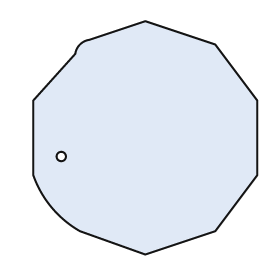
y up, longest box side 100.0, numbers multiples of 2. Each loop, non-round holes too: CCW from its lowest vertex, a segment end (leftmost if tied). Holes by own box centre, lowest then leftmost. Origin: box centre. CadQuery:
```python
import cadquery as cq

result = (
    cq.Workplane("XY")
    .moveTo(0.0, -50.0)
    .lineTo(30.0, -40.0)
    .lineTo(48.0, -16.0)
    .lineTo(48.0, 16.0)
    .lineTo(30.0, 40.0)
    .lineTo(0.0, 50.0)
    .lineTo(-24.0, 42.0)
    .threePointArc((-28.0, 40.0), (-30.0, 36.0))
    .lineTo(-48.0, 16.0)
    .lineTo(-48.0, -16.0)
    .threePointArc((-40.0, -30.0), (-28.0, -40.0))
    .close()
    .moveTo(-36.0, -8.0)
    .circle(2.0)
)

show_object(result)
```